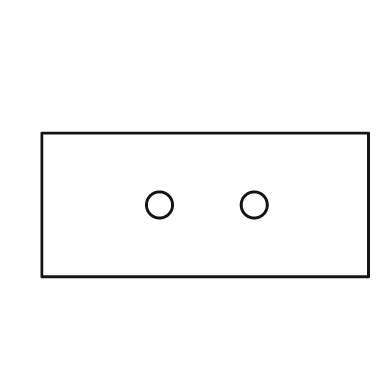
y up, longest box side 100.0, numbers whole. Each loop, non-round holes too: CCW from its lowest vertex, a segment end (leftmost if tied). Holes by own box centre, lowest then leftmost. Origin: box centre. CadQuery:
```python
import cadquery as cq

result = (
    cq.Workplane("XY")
    .moveTo(-50.0, -22.0)
    .lineTo(50.0, -22.0)
    .lineTo(50.0, 22.0)
    .lineTo(-50.0, 22.0)
    .close()
    .moveTo(-14.0, 0.0)
    .circle(4.0)
    .moveTo(15.0, 0.0)
    .circle(4.0)
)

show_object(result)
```